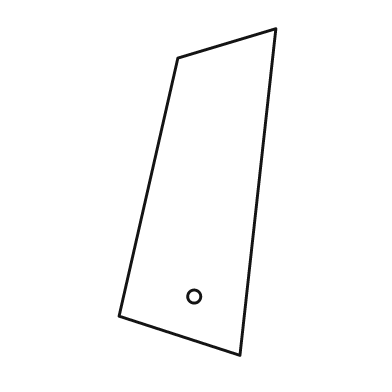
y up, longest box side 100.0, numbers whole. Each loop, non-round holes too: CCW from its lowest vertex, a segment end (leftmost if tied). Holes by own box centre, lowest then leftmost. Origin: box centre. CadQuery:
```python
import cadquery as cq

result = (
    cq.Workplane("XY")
    .moveTo(13.0, -50.0)
    .lineTo(24.0, 50.0)
    .lineTo(-6.0, 41.0)
    .lineTo(-24.0, -38.0)
    .close()
    .moveTo(-1.0, -32.0)
    .circle(2.0)
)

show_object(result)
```